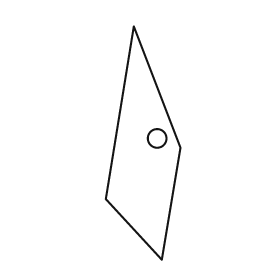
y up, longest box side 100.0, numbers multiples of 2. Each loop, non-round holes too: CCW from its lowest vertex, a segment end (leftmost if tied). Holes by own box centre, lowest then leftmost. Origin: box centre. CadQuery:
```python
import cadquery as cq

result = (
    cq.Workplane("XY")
    .moveTo(8.0, -50.0)
    .lineTo(16.0, -2.0)
    .lineTo(-4.0, 50.0)
    .lineTo(-16.0, -24.0)
    .close()
    .moveTo(6.0, 2.0)
    .circle(4.0)
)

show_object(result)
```